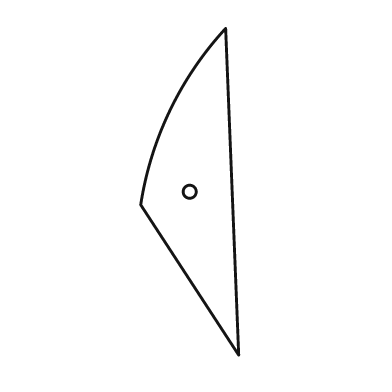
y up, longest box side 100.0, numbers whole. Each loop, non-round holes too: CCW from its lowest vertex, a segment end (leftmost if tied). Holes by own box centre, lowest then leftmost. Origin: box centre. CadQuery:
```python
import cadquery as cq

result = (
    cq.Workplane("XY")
    .moveTo(15.0, -50.0)
    .lineTo(11.0, 50.0)
    .threePointArc((-6.0, 25.0), (-15.0, -4.0))
    .close()
    .moveTo(0.0, 0.0)
    .circle(2.0)
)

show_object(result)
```